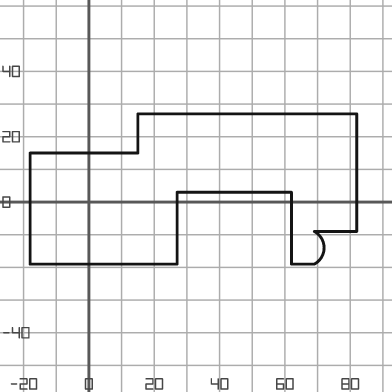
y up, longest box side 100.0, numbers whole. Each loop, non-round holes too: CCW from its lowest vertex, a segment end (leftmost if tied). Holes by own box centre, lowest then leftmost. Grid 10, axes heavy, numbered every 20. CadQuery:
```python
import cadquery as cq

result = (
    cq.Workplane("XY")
    .moveTo(-18.0, -19.0)
    .lineTo(27.0, -19.0)
    .lineTo(27.0, 3.0)
    .lineTo(62.0, 3.0)
    .lineTo(62.0, -19.0)
    .lineTo(69.0, -19.0)
    .threePointArc((72.0, -14.0), (69.0, -9.0))
    .lineTo(82.0, -9.0)
    .lineTo(82.0, 27.0)
    .lineTo(15.0, 27.0)
    .lineTo(15.0, 15.0)
    .lineTo(-18.0, 15.0)
    .close()
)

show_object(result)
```